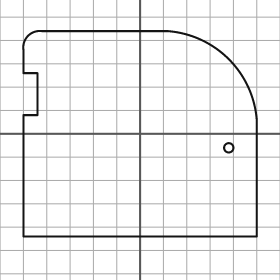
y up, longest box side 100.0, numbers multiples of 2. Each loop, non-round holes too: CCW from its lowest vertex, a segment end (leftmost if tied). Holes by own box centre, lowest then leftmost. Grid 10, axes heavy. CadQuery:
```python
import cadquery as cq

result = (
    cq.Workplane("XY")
    .moveTo(-50.0, -44.0)
    .lineTo(50.0, -44.0)
    .lineTo(50.0, 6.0)
    .threePointArc((38.0, 32.0), (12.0, 44.0))
    .lineTo(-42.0, 44.0)
    .threePointArc((-48.0, 42.0), (-50.0, 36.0))
    .lineTo(-50.0, 26.0)
    .lineTo(-44.0, 26.0)
    .lineTo(-44.0, 8.0)
    .lineTo(-50.0, 8.0)
    .close()
    .moveTo(38.0, -6.0)
    .circle(2.0)
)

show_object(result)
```